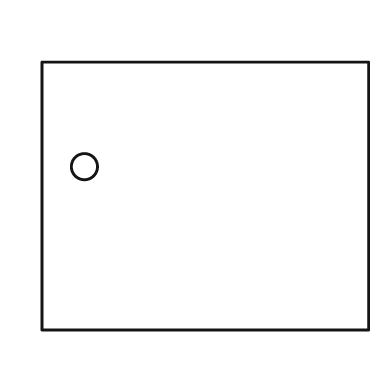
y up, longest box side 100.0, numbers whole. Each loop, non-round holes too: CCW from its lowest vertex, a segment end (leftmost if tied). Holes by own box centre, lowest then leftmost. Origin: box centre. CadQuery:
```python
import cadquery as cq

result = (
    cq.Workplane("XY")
    .moveTo(-50.0, -41.0)
    .lineTo(50.0, -41.0)
    .lineTo(50.0, 41.0)
    .lineTo(-50.0, 41.0)
    .close()
    .moveTo(-37.0, 9.0)
    .circle(4.0)
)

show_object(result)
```